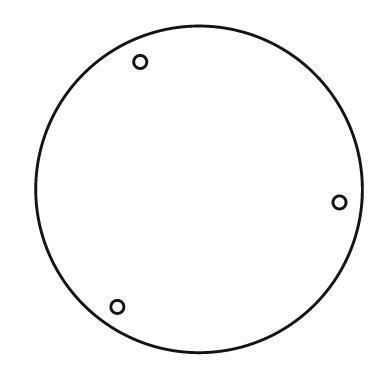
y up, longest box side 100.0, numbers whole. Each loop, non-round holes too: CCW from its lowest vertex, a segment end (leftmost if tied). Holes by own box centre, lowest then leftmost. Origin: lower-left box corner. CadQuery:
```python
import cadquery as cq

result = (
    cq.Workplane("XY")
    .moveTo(50.0, 50.0)
    .circle(50.0)
    .moveTo(25.0, 14.0)
    .circle(2.0)
    .moveTo(93.0, 46.0)
    .circle(2.0)
    .moveTo(32.0, 89.0)
    .circle(2.0)
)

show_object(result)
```